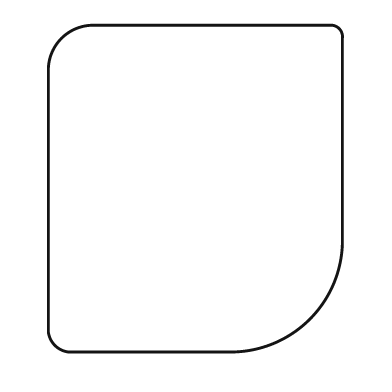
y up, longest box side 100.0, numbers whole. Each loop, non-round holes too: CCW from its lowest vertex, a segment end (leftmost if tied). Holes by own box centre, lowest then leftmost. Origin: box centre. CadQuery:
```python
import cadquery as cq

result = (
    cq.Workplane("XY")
    .moveTo(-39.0, -50.0)
    .lineTo(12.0, -50.0)
    .threePointArc((35.0, -40.0), (45.0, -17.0))
    .lineTo(45.0, 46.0)
    .threePointArc((44.0, 49.0), (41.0, 50.0))
    .lineTo(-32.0, 50.0)
    .threePointArc((-41.0, 46.0), (-45.0, 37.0))
    .lineTo(-45.0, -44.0)
    .threePointArc((-43.0, -48.0), (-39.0, -50.0))
    .close()
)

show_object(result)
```